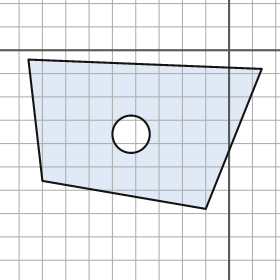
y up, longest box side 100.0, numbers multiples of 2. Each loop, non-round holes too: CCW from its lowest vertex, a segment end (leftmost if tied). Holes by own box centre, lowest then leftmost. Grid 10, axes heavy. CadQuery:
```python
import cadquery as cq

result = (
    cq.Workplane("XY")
    .moveTo(-10.0, -68.0)
    .lineTo(14.0, -8.0)
    .lineTo(-86.0, -4.0)
    .lineTo(-80.0, -56.0)
    .close()
    .moveTo(-42.0, -36.0)
    .circle(8.0)
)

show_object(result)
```